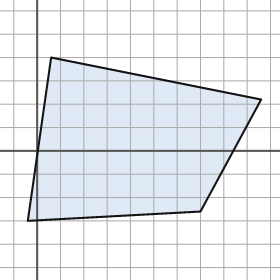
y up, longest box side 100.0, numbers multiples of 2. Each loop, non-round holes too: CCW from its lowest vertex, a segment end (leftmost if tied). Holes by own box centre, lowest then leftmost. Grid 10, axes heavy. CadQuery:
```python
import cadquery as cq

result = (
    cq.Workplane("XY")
    .moveTo(-4.0, -30.0)
    .lineTo(70.0, -26.0)
    .lineTo(96.0, 22.0)
    .lineTo(6.0, 40.0)
    .close()
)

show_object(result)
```